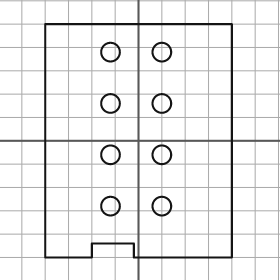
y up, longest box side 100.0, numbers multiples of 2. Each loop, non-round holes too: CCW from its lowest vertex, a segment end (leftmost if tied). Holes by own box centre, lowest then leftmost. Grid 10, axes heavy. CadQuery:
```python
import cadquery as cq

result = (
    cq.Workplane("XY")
    .moveTo(-40.0, -50.0)
    .lineTo(-20.0, -50.0)
    .lineTo(-20.0, -44.0)
    .lineTo(-2.0, -44.0)
    .lineTo(-2.0, -50.0)
    .lineTo(40.0, -50.0)
    .lineTo(40.0, 50.0)
    .lineTo(-40.0, 50.0)
    .close()
    .moveTo(-12.0, -28.0)
    .circle(4.0)
    .moveTo(10.0, -28.0)
    .circle(4.0)
    .moveTo(-12.0, -6.0)
    .circle(4.0)
    .moveTo(10.0, -6.0)
    .circle(4.0)
    .moveTo(-12.0, 16.0)
    .circle(4.0)
    .moveTo(10.0, 16.0)
    .circle(4.0)
    .moveTo(-12.0, 38.0)
    .circle(4.0)
    .moveTo(10.0, 38.0)
    .circle(4.0)
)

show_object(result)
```